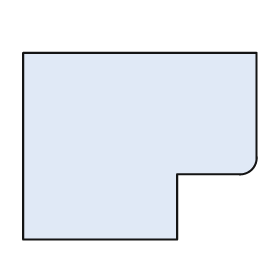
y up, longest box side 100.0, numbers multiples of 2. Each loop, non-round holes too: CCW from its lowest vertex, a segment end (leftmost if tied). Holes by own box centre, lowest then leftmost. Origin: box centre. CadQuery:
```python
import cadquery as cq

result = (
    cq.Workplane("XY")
    .moveTo(-50.0, -40.0)
    .lineTo(16.0, -40.0)
    .lineTo(16.0, -12.0)
    .lineTo(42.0, -12.0)
    .threePointArc((48.0, -10.0), (50.0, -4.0))
    .lineTo(50.0, 40.0)
    .lineTo(-50.0, 40.0)
    .close()
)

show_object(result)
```